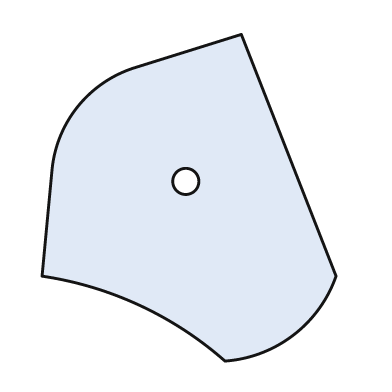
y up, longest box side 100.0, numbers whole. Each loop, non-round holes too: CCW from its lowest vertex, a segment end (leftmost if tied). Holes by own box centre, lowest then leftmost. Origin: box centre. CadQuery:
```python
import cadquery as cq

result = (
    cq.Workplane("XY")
    .moveTo(11.0, -50.0)
    .threePointArc((32.0, -42.0), (45.0, -24.0))
    .lineTo(16.0, 50.0)
    .lineTo(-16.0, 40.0)
    .threePointArc((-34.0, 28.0), (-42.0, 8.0))
    .lineTo(-45.0, -24.0)
    .threePointArc((-15.0, -33.0), (11.0, -50.0))
    .close()
    .moveTo(-1.0, 5.0)
    .circle(4.0)
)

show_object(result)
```